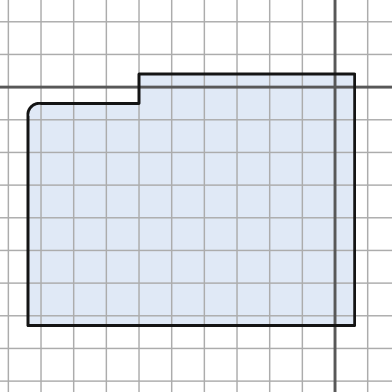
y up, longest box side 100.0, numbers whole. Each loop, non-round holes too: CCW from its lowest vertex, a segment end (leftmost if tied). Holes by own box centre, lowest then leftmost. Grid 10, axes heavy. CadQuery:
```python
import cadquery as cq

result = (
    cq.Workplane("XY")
    .moveTo(-94.0, -73.0)
    .lineTo(6.0, -73.0)
    .lineTo(6.0, 4.0)
    .lineTo(-60.0, 4.0)
    .lineTo(-60.0, -5.0)
    .lineTo(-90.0, -5.0)
    .threePointArc((-93.0, -6.0), (-94.0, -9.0))
    .close()
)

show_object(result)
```